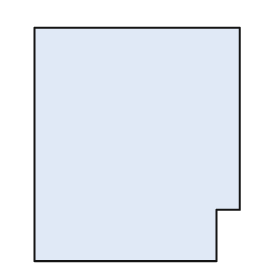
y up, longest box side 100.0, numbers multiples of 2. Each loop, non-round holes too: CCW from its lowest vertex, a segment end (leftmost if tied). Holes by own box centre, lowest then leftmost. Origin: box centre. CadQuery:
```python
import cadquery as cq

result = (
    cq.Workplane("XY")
    .moveTo(-44.0, -50.0)
    .lineTo(34.0, -50.0)
    .lineTo(34.0, -28.0)
    .lineTo(44.0, -28.0)
    .lineTo(44.0, 50.0)
    .lineTo(-44.0, 50.0)
    .close()
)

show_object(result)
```